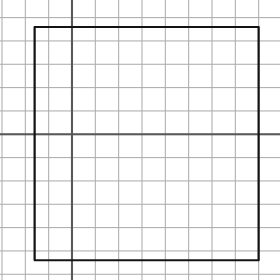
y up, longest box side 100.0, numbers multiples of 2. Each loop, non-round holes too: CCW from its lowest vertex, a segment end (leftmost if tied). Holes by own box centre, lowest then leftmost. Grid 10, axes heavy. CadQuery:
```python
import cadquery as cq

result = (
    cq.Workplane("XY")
    .moveTo(-16.0, -54.0)
    .lineTo(80.0, -54.0)
    .lineTo(80.0, 46.0)
    .lineTo(-16.0, 46.0)
    .close()
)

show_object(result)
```